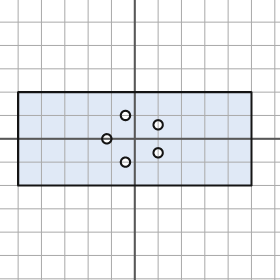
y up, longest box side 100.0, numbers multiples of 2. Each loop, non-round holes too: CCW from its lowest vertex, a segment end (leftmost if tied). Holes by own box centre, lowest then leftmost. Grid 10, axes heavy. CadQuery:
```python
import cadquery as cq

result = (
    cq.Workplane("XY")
    .moveTo(-50.0, -20.0)
    .lineTo(50.0, -20.0)
    .lineTo(50.0, 20.0)
    .lineTo(-50.0, 20.0)
    .close()
    .moveTo(-4.0, -10.0)
    .circle(2.0)
    .moveTo(10.0, -6.0)
    .circle(2.0)
    .moveTo(-12.0, 0.0)
    .circle(2.0)
    .moveTo(10.0, 6.0)
    .circle(2.0)
    .moveTo(-4.0, 10.0)
    .circle(2.0)
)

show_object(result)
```